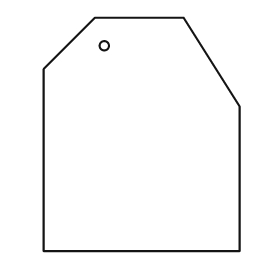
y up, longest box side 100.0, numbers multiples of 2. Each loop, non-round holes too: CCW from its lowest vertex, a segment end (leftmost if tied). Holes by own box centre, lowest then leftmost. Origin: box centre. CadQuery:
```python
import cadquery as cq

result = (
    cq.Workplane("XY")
    .moveTo(-42.0, -50.0)
    .lineTo(42.0, -50.0)
    .lineTo(42.0, 12.0)
    .lineTo(18.0, 50.0)
    .lineTo(-20.0, 50.0)
    .lineTo(-42.0, 28.0)
    .close()
    .moveTo(-16.0, 38.0)
    .circle(2.0)
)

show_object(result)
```